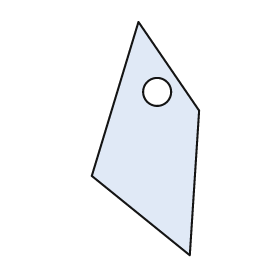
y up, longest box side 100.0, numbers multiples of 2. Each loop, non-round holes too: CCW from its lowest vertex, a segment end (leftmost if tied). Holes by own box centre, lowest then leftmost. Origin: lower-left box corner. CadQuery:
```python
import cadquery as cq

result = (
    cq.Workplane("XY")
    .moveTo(42.0, 0.0)
    .lineTo(46.0, 62.0)
    .lineTo(20.0, 100.0)
    .lineTo(0.0, 34.0)
    .close()
    .moveTo(28.0, 70.0)
    .circle(6.0)
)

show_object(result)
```